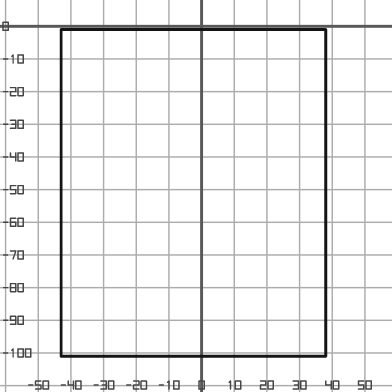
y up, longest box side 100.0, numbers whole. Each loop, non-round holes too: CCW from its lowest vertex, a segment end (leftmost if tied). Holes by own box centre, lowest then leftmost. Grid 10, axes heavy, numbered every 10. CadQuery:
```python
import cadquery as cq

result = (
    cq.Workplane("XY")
    .moveTo(-43.0, -101.0)
    .lineTo(38.0, -101.0)
    .lineTo(38.0, -1.0)
    .lineTo(-43.0, -1.0)
    .close()
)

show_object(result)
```